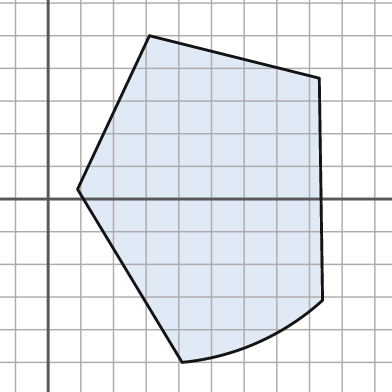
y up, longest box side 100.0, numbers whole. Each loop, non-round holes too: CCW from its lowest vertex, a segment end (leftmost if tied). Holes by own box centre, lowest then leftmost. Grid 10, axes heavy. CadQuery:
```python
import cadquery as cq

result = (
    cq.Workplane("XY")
    .moveTo(41.0, -50.0)
    .threePointArc((64.0, -44.0), (84.0, -31.0))
    .lineTo(83.0, 37.0)
    .lineTo(31.0, 50.0)
    .lineTo(9.0, 3.0)
    .close()
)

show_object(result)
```